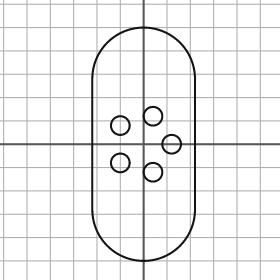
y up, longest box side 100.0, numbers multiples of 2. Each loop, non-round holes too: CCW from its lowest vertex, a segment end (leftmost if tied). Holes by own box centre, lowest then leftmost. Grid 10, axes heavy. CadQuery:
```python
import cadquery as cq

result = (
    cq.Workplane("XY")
    .moveTo(-22.0, -28.0)
    .threePointArc((0.0, -50.0), (22.0, -28.0))
    .lineTo(22.0, 28.0)
    .threePointArc((0.0, 50.0), (-22.0, 28.0))
    .close()
    .moveTo(4.0, -12.0)
    .circle(4.0)
    .moveTo(-10.0, -8.0)
    .circle(4.0)
    .moveTo(12.0, 0.0)
    .circle(4.0)
    .moveTo(-10.0, 8.0)
    .circle(4.0)
    .moveTo(4.0, 12.0)
    .circle(4.0)
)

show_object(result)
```